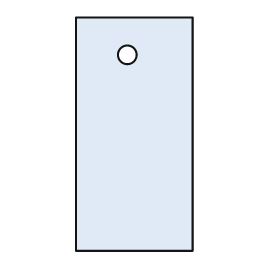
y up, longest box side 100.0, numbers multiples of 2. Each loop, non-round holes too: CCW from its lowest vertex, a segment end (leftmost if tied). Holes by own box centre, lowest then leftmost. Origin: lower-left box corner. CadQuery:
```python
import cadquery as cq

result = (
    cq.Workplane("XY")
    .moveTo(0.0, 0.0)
    .lineTo(50.0, 0.0)
    .lineTo(50.0, 100.0)
    .lineTo(0.0, 100.0)
    .close()
    .moveTo(22.0, 84.0)
    .circle(4.0)
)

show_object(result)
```